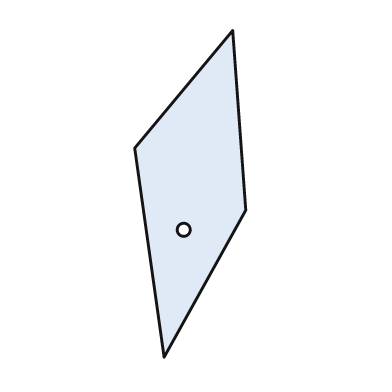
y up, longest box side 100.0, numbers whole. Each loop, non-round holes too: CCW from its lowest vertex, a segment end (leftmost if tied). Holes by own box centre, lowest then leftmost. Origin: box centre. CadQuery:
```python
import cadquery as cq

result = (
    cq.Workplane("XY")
    .moveTo(-8.0, -50.0)
    .lineTo(17.0, -5.0)
    .lineTo(13.0, 50.0)
    .lineTo(-17.0, 14.0)
    .close()
    .moveTo(-2.0, -11.0)
    .circle(2.0)
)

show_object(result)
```